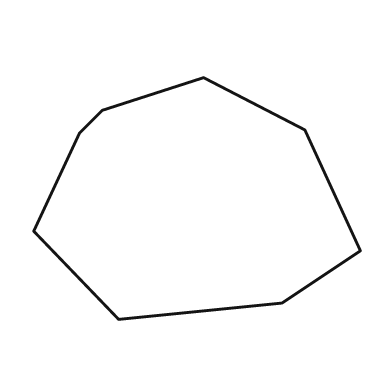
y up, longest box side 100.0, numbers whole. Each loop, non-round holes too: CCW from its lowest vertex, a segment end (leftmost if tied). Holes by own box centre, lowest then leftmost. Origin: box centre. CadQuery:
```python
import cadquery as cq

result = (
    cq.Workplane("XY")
    .moveTo(-24.0, -37.0)
    .lineTo(26.0, -32.0)
    .lineTo(50.0, -16.0)
    .lineTo(33.0, 21.0)
    .lineTo(2.0, 37.0)
    .lineTo(-29.0, 27.0)
    .lineTo(-36.0, 20.0)
    .lineTo(-50.0, -10.0)
    .close()
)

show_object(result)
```